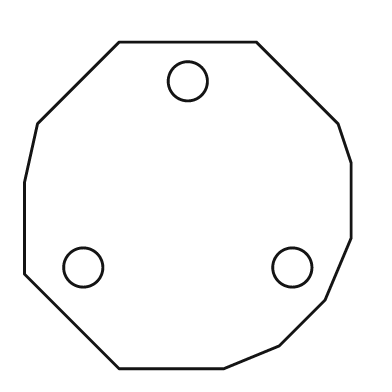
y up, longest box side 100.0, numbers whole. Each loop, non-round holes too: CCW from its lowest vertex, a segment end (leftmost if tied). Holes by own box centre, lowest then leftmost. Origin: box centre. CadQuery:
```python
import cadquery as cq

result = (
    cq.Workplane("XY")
    .moveTo(-21.0, -50.0)
    .lineTo(11.0, -50.0)
    .lineTo(28.0, -43.0)
    .lineTo(42.0, -29.0)
    .lineTo(50.0, -10.0)
    .lineTo(50.0, 13.0)
    .lineTo(46.0, 25.0)
    .lineTo(21.0, 50.0)
    .lineTo(-21.0, 50.0)
    .lineTo(-46.0, 25.0)
    .lineTo(-50.0, 7.0)
    .lineTo(-50.0, -21.0)
    .close()
    .moveTo(-32.0, -19.0)
    .circle(6.0)
    .moveTo(32.0, -19.0)
    .circle(6.0)
    .moveTo(0.0, 38.0)
    .circle(6.0)
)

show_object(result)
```